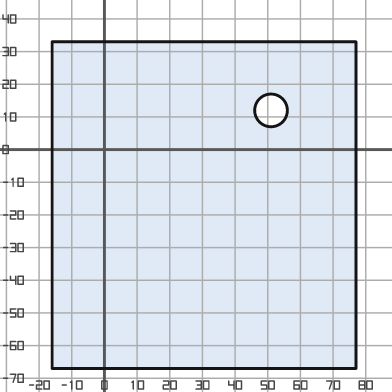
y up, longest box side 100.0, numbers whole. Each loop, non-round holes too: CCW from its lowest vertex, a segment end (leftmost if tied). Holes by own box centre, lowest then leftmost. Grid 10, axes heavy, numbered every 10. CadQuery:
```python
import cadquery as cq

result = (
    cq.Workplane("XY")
    .moveTo(-16.0, -67.0)
    .lineTo(77.0, -67.0)
    .lineTo(77.0, 33.0)
    .lineTo(-16.0, 33.0)
    .close()
    .moveTo(51.0, 12.0)
    .circle(5.0)
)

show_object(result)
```